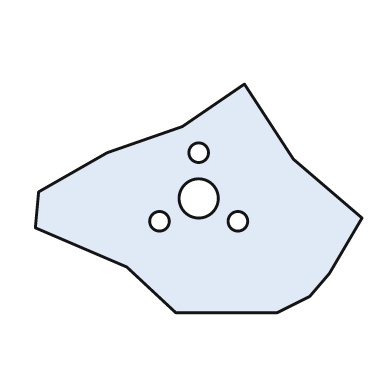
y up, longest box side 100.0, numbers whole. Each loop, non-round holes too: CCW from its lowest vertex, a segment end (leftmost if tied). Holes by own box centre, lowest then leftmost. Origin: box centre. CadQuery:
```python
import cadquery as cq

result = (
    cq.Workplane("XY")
    .moveTo(-7.0, -35.0)
    .lineTo(24.0, -35.0)
    .lineTo(34.0, -30.0)
    .lineTo(40.0, -23.0)
    .lineTo(50.0, -6.0)
    .lineTo(29.0, 12.0)
    .lineTo(14.0, 35.0)
    .lineTo(-5.0, 22.0)
    .lineTo(-28.0, 14.0)
    .lineTo(-49.0, 2.0)
    .lineTo(-50.0, -9.0)
    .lineTo(-22.0, -21.0)
    .close()
    .moveTo(-12.0, -7.0)
    .circle(3.0)
    .moveTo(12.0, -7.0)
    .circle(3.0)
    .moveTo(0.0, 0.0)
    .circle(6.0)
    .moveTo(0.0, 14.0)
    .circle(3.0)
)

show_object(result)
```